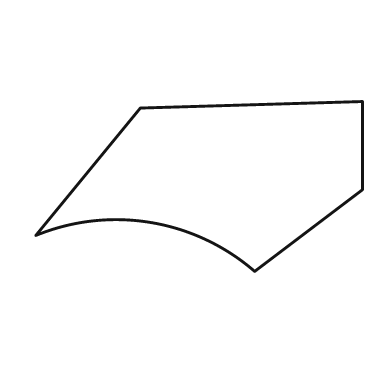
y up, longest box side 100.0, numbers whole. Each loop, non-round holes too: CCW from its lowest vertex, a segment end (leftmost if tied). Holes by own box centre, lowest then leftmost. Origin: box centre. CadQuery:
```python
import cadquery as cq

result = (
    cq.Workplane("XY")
    .moveTo(17.0, -26.0)
    .lineTo(50.0, -1.0)
    .lineTo(50.0, 26.0)
    .lineTo(-18.0, 24.0)
    .lineTo(-50.0, -15.0)
    .threePointArc((-15.0, -11.0), (17.0, -26.0))
    .close()
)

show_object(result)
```